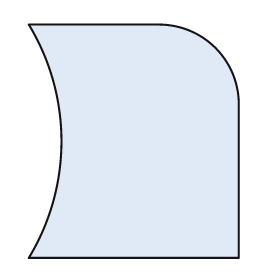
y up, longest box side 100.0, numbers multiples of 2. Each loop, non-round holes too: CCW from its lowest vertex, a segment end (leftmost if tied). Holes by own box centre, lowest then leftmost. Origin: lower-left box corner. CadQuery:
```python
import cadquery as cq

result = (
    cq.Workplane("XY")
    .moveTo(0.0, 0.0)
    .lineTo(90.0, 0.0)
    .lineTo(90.0, 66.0)
    .threePointArc((80.0, 90.0), (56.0, 100.0))
    .lineTo(0.0, 100.0)
    .threePointArc((14.0, 50.0), (0.0, 0.0))
    .close()
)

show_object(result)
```